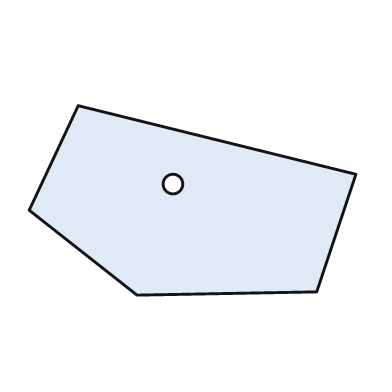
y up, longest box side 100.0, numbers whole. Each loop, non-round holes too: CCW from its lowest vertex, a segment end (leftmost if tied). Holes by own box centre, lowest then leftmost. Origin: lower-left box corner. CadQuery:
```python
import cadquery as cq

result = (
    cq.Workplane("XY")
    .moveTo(33.0, 0.0)
    .lineTo(88.0, 1.0)
    .lineTo(100.0, 37.0)
    .lineTo(15.0, 58.0)
    .lineTo(0.0, 26.0)
    .close()
    .moveTo(44.0, 34.0)
    .circle(3.0)
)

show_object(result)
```